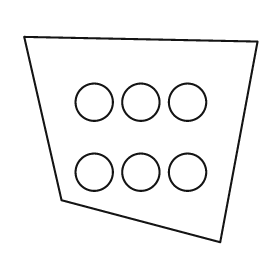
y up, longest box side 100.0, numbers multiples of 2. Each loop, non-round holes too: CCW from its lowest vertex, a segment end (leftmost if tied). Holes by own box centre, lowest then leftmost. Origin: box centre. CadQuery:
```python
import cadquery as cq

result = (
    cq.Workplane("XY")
    .moveTo(34.0, -44.0)
    .lineTo(50.0, 42.0)
    .lineTo(-50.0, 44.0)
    .lineTo(-34.0, -26.0)
    .close()
    .moveTo(-20.0, -14.0)
    .circle(8.0)
    .moveTo(0.0, -14.0)
    .circle(8.0)
    .moveTo(20.0, -14.0)
    .circle(8.0)
    .moveTo(-20.0, 16.0)
    .circle(8.0)
    .moveTo(0.0, 16.0)
    .circle(8.0)
    .moveTo(20.0, 16.0)
    .circle(8.0)
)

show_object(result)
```